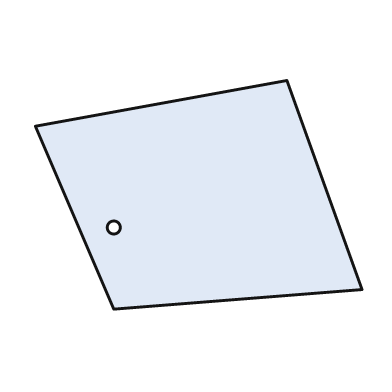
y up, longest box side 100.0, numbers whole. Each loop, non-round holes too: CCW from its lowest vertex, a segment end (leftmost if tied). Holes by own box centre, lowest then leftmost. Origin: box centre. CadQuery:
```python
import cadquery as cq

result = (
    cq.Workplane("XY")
    .moveTo(-26.0, -35.0)
    .lineTo(50.0, -29.0)
    .lineTo(27.0, 35.0)
    .lineTo(-50.0, 21.0)
    .close()
    .moveTo(-26.0, -10.0)
    .circle(2.0)
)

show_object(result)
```